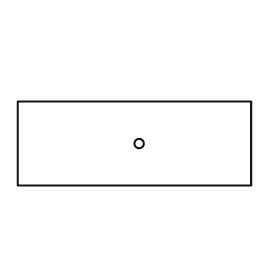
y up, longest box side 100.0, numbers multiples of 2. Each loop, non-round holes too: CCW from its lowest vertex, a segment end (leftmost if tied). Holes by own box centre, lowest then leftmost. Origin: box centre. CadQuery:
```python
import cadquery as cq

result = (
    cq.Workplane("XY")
    .moveTo(-50.0, -18.0)
    .lineTo(50.0, -18.0)
    .lineTo(50.0, 18.0)
    .lineTo(-50.0, 18.0)
    .close()
    .moveTo(2.0, 0.0)
    .circle(2.0)
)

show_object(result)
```